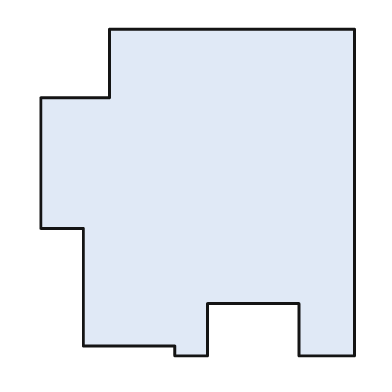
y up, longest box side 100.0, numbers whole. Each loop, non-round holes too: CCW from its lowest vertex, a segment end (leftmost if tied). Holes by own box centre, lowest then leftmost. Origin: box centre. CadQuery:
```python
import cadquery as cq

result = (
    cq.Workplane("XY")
    .moveTo(-7.0, -50.0)
    .lineTo(3.0, -50.0)
    .lineTo(3.0, -34.0)
    .lineTo(31.0, -34.0)
    .lineTo(31.0, -50.0)
    .lineTo(48.0, -50.0)
    .lineTo(48.0, 50.0)
    .lineTo(-27.0, 50.0)
    .lineTo(-27.0, 29.0)
    .lineTo(-48.0, 29.0)
    .lineTo(-48.0, -11.0)
    .lineTo(-35.0, -11.0)
    .lineTo(-35.0, -47.0)
    .lineTo(-7.0, -47.0)
    .close()
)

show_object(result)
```